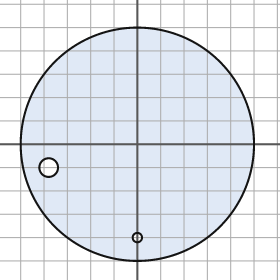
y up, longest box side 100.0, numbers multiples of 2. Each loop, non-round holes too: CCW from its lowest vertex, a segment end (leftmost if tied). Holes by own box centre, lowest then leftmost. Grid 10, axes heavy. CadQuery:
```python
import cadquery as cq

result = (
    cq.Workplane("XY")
    .moveTo(0.0, 0.0)
    .circle(50.0)
    .moveTo(0.0, -40.0)
    .circle(2.0)
    .moveTo(-38.0, -10.0)
    .circle(4.0)
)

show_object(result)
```